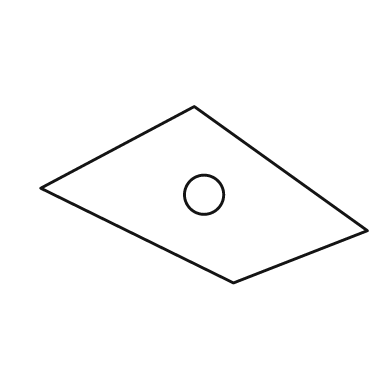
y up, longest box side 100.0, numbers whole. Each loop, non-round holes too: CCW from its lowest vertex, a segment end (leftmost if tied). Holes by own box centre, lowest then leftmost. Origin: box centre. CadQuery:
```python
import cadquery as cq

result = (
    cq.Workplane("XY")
    .moveTo(9.0, -27.0)
    .lineTo(50.0, -11.0)
    .lineTo(-3.0, 27.0)
    .lineTo(-50.0, 2.0)
    .close()
    .moveTo(0.0, 0.0)
    .circle(6.0)
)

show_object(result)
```